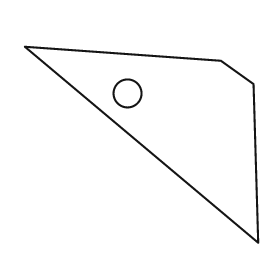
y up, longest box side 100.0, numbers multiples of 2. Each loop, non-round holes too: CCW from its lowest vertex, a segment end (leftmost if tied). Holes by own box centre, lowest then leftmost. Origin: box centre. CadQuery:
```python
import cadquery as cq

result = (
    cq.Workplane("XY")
    .moveTo(50.0, -42.0)
    .lineTo(48.0, 26.0)
    .lineTo(34.0, 36.0)
    .lineTo(-50.0, 42.0)
    .close()
    .moveTo(-6.0, 22.0)
    .circle(6.0)
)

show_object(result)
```